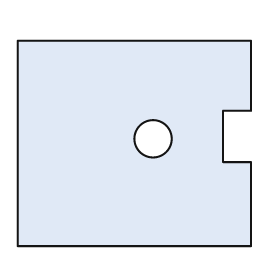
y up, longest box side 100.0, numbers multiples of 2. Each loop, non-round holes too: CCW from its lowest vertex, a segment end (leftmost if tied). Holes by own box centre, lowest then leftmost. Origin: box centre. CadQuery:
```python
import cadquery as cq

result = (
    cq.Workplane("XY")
    .moveTo(-50.0, -44.0)
    .lineTo(50.0, -44.0)
    .lineTo(50.0, -8.0)
    .lineTo(38.0, -8.0)
    .lineTo(38.0, 14.0)
    .lineTo(50.0, 14.0)
    .lineTo(50.0, 44.0)
    .lineTo(-50.0, 44.0)
    .close()
    .moveTo(8.0, 2.0)
    .circle(8.0)
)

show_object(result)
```